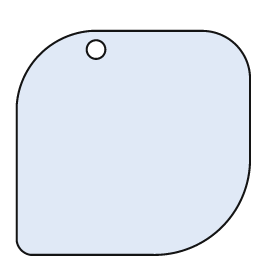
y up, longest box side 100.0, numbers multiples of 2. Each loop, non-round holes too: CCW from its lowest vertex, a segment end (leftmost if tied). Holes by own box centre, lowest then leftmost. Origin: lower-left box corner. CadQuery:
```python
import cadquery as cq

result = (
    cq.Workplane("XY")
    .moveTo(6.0, 0.0)
    .lineTo(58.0, 0.0)
    .threePointArc((88.0, 12.0), (100.0, 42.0))
    .lineTo(100.0, 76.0)
    .threePointArc((94.0, 90.0), (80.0, 96.0))
    .lineTo(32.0, 96.0)
    .threePointArc((10.0, 86.0), (0.0, 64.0))
    .lineTo(0.0, 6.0)
    .threePointArc((2.0, 2.0), (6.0, 0.0))
    .close()
    .moveTo(34.0, 88.0)
    .circle(4.0)
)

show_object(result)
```